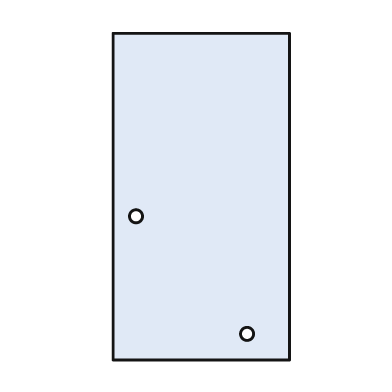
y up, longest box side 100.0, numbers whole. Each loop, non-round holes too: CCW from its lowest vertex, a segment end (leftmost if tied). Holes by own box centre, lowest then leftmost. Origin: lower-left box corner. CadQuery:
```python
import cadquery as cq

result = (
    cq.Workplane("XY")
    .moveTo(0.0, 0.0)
    .lineTo(54.0, 0.0)
    .lineTo(54.0, 100.0)
    .lineTo(0.0, 100.0)
    .close()
    .moveTo(41.0, 8.0)
    .circle(2.0)
    .moveTo(7.0, 44.0)
    .circle(2.0)
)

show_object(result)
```